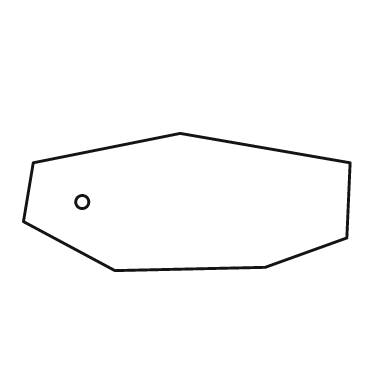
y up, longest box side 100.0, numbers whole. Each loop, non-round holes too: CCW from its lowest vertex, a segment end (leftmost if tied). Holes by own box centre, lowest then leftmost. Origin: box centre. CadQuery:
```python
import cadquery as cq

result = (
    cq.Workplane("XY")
    .moveTo(-22.0, -21.0)
    .lineTo(24.0, -20.0)
    .lineTo(49.0, -11.0)
    .lineTo(50.0, 12.0)
    .lineTo(-2.0, 21.0)
    .lineTo(-47.0, 12.0)
    .lineTo(-50.0, -6.0)
    .close()
    .moveTo(-32.0, 0.0)
    .circle(2.0)
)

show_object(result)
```